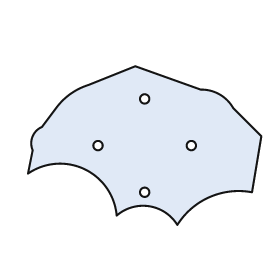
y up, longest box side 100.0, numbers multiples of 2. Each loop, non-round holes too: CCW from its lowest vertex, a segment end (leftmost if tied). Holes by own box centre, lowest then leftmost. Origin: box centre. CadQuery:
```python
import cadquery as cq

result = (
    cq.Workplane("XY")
    .moveTo(14.0, -34.0)
    .threePointArc((28.0, -22.0), (46.0, -20.0))
    .lineTo(50.0, 4.0)
    .lineTo(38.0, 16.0)
    .threePointArc((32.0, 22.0), (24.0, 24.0))
    .lineTo(-4.0, 34.0)
    .lineTo(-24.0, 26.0)
    .threePointArc((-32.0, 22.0), (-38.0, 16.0))
    .lineTo(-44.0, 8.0)
    .threePointArc((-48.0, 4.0), (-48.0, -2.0))
    .lineTo(-50.0, -12.0)
    .threePointArc((-26.0, -10.0), (-12.0, -30.0))
    .threePointArc((2.0, -26.0), (14.0, -34.0))
    .close()
    .moveTo(0.0, -20.0)
    .circle(2.0)
    .moveTo(-20.0, 0.0)
    .circle(2.0)
    .moveTo(20.0, 0.0)
    .circle(2.0)
    .moveTo(0.0, 20.0)
    .circle(2.0)
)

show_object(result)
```